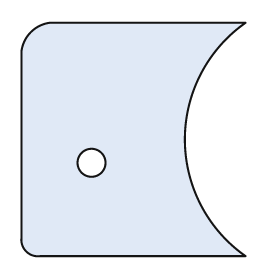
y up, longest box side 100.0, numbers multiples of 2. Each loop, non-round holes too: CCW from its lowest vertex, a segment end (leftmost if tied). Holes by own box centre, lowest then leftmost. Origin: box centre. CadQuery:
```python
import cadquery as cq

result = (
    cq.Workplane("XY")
    .moveTo(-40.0, -50.0)
    .lineTo(48.0, -50.0)
    .threePointArc((22.0, 0.0), (48.0, 50.0))
    .lineTo(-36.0, 50.0)
    .threePointArc((-44.0, 46.0), (-48.0, 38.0))
    .lineTo(-48.0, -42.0)
    .threePointArc((-46.0, -48.0), (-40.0, -50.0))
    .close()
    .moveTo(-18.0, -10.0)
    .circle(6.0)
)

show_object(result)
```